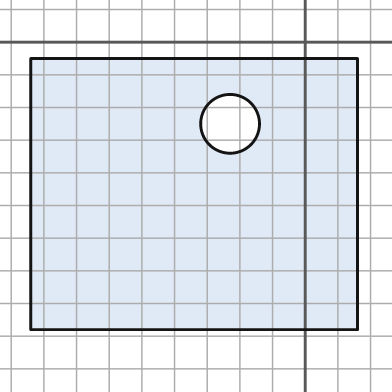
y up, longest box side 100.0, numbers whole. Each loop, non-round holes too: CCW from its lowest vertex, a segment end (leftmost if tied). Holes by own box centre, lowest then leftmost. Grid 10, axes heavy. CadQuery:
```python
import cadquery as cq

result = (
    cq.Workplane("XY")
    .moveTo(-84.0, -88.0)
    .lineTo(16.0, -88.0)
    .lineTo(16.0, -5.0)
    .lineTo(-84.0, -5.0)
    .close()
    .moveTo(-23.0, -25.0)
    .circle(9.0)
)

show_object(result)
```